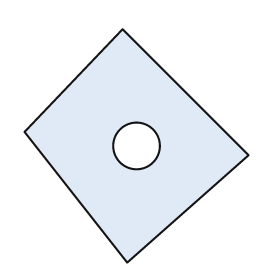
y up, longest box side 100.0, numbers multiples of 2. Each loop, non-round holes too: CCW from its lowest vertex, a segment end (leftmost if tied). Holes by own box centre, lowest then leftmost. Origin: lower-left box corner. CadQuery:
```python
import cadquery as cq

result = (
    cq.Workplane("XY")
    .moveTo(44.0, 0.0)
    .lineTo(96.0, 46.0)
    .lineTo(42.0, 100.0)
    .lineTo(0.0, 56.0)
    .close()
    .moveTo(48.0, 50.0)
    .circle(10.0)
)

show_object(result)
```